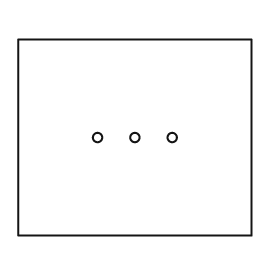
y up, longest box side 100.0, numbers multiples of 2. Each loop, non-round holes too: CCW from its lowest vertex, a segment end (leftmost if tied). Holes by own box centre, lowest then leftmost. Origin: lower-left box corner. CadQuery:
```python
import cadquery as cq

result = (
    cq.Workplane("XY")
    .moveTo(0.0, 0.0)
    .lineTo(100.0, 0.0)
    .lineTo(100.0, 84.0)
    .lineTo(0.0, 84.0)
    .close()
    .moveTo(34.0, 42.0)
    .circle(2.0)
    .moveTo(50.0, 42.0)
    .circle(2.0)
    .moveTo(66.0, 42.0)
    .circle(2.0)
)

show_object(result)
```